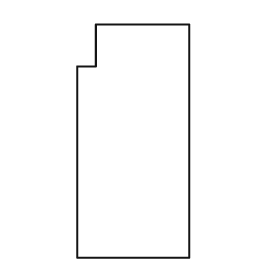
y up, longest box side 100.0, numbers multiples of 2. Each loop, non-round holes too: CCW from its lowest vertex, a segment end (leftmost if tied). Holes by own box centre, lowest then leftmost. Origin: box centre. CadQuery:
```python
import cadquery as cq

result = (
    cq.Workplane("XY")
    .moveTo(-24.0, -50.0)
    .lineTo(24.0, -50.0)
    .lineTo(24.0, 50.0)
    .lineTo(-16.0, 50.0)
    .lineTo(-16.0, 32.0)
    .lineTo(-24.0, 32.0)
    .close()
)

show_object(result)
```